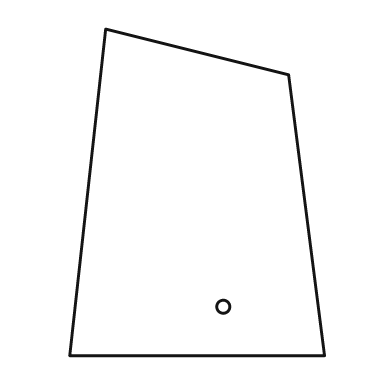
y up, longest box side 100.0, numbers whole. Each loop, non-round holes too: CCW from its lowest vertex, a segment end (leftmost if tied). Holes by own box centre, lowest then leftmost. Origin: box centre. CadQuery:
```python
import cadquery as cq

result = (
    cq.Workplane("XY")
    .moveTo(-39.0, -50.0)
    .lineTo(39.0, -50.0)
    .lineTo(28.0, 36.0)
    .lineTo(-28.0, 50.0)
    .close()
    .moveTo(8.0, -35.0)
    .circle(2.0)
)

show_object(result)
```